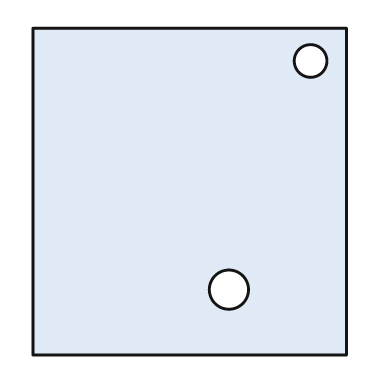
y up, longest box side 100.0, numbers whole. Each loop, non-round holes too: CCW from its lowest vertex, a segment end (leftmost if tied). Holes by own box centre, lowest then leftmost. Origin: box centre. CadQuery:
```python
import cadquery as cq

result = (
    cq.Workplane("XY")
    .moveTo(-48.0, -50.0)
    .lineTo(48.0, -50.0)
    .lineTo(48.0, 50.0)
    .lineTo(-48.0, 50.0)
    .close()
    .moveTo(12.0, -30.0)
    .circle(6.0)
    .moveTo(37.0, 40.0)
    .circle(5.0)
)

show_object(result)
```